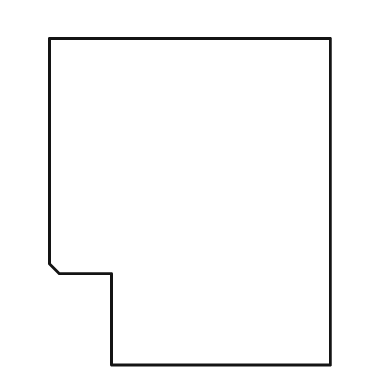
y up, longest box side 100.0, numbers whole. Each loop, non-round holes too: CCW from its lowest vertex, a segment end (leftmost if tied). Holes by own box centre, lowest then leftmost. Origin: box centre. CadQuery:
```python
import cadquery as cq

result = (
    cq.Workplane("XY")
    .moveTo(-24.0, -50.0)
    .lineTo(43.0, -50.0)
    .lineTo(43.0, 50.0)
    .lineTo(-43.0, 50.0)
    .lineTo(-43.0, -19.0)
    .lineTo(-40.0, -22.0)
    .lineTo(-24.0, -22.0)
    .close()
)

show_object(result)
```